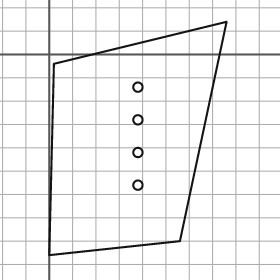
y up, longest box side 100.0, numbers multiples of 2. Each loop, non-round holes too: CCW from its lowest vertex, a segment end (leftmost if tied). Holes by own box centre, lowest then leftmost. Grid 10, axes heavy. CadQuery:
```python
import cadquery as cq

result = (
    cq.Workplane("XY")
    .moveTo(0.0, -86.0)
    .lineTo(56.0, -80.0)
    .lineTo(76.0, 14.0)
    .lineTo(2.0, -4.0)
    .close()
    .moveTo(38.0, -56.0)
    .circle(2.0)
    .moveTo(38.0, -42.0)
    .circle(2.0)
    .moveTo(38.0, -28.0)
    .circle(2.0)
    .moveTo(38.0, -14.0)
    .circle(2.0)
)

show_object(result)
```